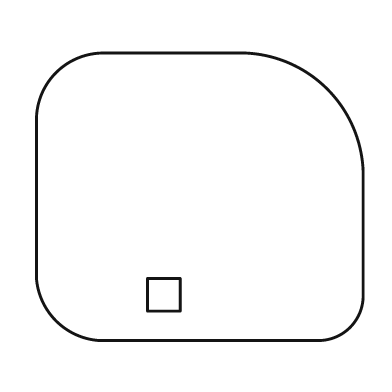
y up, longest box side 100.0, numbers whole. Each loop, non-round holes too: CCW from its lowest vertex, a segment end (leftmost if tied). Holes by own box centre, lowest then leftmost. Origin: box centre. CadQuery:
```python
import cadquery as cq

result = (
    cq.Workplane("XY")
    .moveTo(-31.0, -44.0)
    .lineTo(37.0, -44.0)
    .threePointArc((46.0, -40.0), (50.0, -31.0))
    .lineTo(50.0, 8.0)
    .threePointArc((39.0, 33.0), (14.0, 44.0))
    .lineTo(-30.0, 44.0)
    .threePointArc((-44.0, 38.0), (-50.0, 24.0))
    .lineTo(-50.0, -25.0)
    .threePointArc((-44.0, -38.0), (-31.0, -44.0))
    .close()
    .moveTo(-16.0, -35.0)
    .lineTo(-6.0, -35.0)
    .lineTo(-6.0, -25.0)
    .lineTo(-16.0, -25.0)
    .close()
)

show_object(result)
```